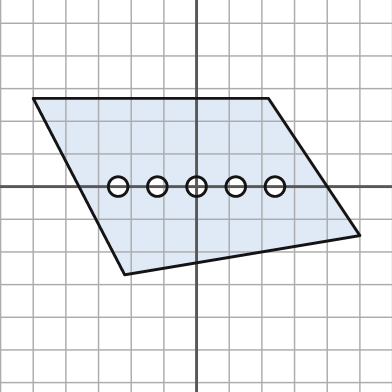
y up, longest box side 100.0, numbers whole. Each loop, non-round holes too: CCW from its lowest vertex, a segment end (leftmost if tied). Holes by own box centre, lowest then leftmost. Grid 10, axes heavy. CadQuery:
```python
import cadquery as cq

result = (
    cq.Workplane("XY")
    .moveTo(-22.0, -27.0)
    .lineTo(50.0, -15.0)
    .lineTo(22.0, 27.0)
    .lineTo(-50.0, 27.0)
    .close()
    .moveTo(-24.0, 0.0)
    .circle(3.0)
    .moveTo(-12.0, 0.0)
    .circle(3.0)
    .moveTo(0.0, 0.0)
    .circle(3.0)
    .moveTo(12.0, 0.0)
    .circle(3.0)
    .moveTo(24.0, 0.0)
    .circle(3.0)
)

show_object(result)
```